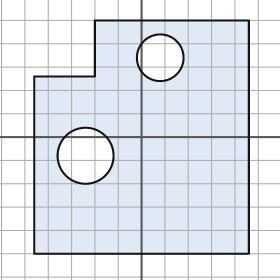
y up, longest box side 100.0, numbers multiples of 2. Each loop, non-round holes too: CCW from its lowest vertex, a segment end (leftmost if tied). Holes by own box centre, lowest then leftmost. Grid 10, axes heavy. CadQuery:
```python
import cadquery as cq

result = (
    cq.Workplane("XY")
    .moveTo(-46.0, -50.0)
    .lineTo(46.0, -50.0)
    .lineTo(46.0, 50.0)
    .lineTo(-20.0, 50.0)
    .lineTo(-20.0, 26.0)
    .lineTo(-46.0, 26.0)
    .close()
    .moveTo(-24.0, -8.0)
    .circle(12.0)
    .moveTo(8.0, 34.0)
    .circle(10.0)
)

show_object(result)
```